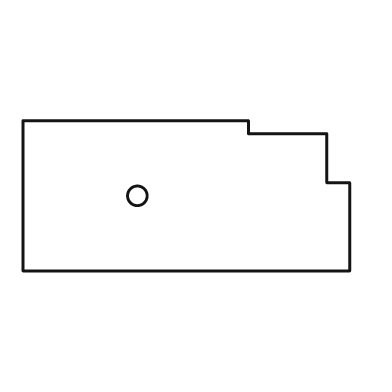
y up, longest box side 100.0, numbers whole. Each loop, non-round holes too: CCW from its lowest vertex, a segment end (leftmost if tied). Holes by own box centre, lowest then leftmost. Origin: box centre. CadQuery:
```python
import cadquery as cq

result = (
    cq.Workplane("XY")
    .moveTo(-50.0, -23.0)
    .lineTo(50.0, -23.0)
    .lineTo(50.0, 4.0)
    .lineTo(43.0, 4.0)
    .lineTo(43.0, 19.0)
    .lineTo(19.0, 19.0)
    .lineTo(19.0, 23.0)
    .lineTo(-50.0, 23.0)
    .close()
    .moveTo(-15.0, 0.0)
    .circle(3.0)
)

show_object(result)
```